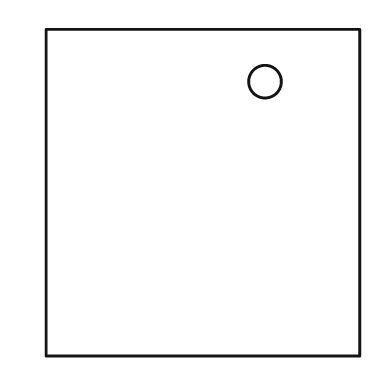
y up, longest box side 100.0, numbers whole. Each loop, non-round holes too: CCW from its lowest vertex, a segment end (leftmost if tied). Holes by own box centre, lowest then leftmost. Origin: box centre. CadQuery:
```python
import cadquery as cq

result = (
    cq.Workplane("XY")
    .moveTo(-48.0, -50.0)
    .lineTo(48.0, -50.0)
    .lineTo(48.0, 50.0)
    .lineTo(-48.0, 50.0)
    .close()
    .moveTo(19.0, 34.0)
    .circle(5.0)
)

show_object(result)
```